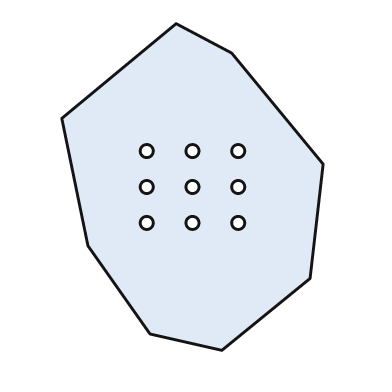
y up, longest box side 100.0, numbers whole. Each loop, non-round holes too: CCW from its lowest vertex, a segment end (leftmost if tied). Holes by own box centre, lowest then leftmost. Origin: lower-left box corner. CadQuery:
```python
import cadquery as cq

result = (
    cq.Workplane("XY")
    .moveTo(49.0, 0.0)
    .lineTo(76.0, 22.0)
    .lineTo(80.0, 57.0)
    .lineTo(52.0, 91.0)
    .lineTo(35.0, 100.0)
    .lineTo(0.0, 71.0)
    .lineTo(8.0, 32.0)
    .lineTo(27.0, 5.0)
    .close()
    .moveTo(26.0, 39.0)
    .circle(2.0)
    .moveTo(40.0, 39.0)
    .circle(2.0)
    .moveTo(54.0, 39.0)
    .circle(2.0)
    .moveTo(26.0, 50.0)
    .circle(2.0)
    .moveTo(40.0, 50.0)
    .circle(2.0)
    .moveTo(54.0, 50.0)
    .circle(2.0)
    .moveTo(26.0, 61.0)
    .circle(2.0)
    .moveTo(40.0, 61.0)
    .circle(2.0)
    .moveTo(54.0, 61.0)
    .circle(2.0)
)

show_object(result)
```